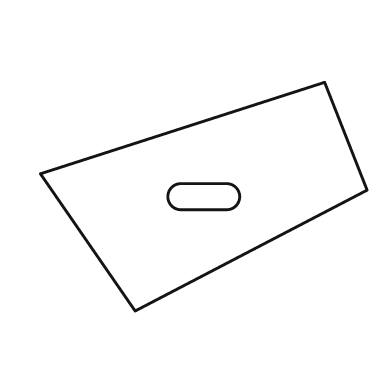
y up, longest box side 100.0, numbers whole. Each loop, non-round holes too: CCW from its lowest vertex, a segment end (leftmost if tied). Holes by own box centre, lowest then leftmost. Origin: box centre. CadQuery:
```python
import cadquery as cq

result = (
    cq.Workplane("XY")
    .moveTo(-21.0, -35.0)
    .lineTo(50.0, 2.0)
    .lineTo(37.0, 35.0)
    .lineTo(-50.0, 7.0)
    .close()
    .moveTo(-7.0, -4.0)
    .lineTo(7.0, -4.0)
    .threePointArc((11.0, 0.0), (7.0, 4.0))
    .lineTo(-7.0, 4.0)
    .threePointArc((-11.0, 0.0), (-7.0, -4.0))
    .close()
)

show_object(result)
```